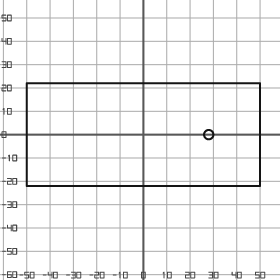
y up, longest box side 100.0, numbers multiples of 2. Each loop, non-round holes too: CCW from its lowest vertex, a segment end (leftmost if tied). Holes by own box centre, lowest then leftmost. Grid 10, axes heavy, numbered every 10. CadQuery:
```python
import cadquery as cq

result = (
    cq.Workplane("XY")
    .moveTo(-50.0, -22.0)
    .lineTo(50.0, -22.0)
    .lineTo(50.0, 22.0)
    .lineTo(-50.0, 22.0)
    .close()
    .moveTo(28.0, 0.0)
    .circle(2.0)
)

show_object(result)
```